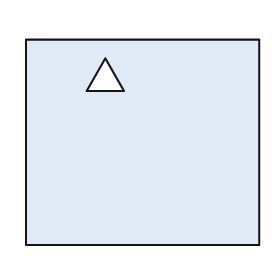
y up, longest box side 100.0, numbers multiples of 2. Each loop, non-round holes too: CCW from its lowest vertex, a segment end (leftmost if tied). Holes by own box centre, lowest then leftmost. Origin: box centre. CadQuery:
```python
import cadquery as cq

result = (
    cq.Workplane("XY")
    .moveTo(-50.0, -44.0)
    .lineTo(50.0, -44.0)
    .lineTo(50.0, 44.0)
    .lineTo(-50.0, 44.0)
    .close()
    .moveTo(-24.0, 22.0)
    .lineTo(-8.0, 22.0)
    .lineTo(-16.0, 36.0)
    .close()
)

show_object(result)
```